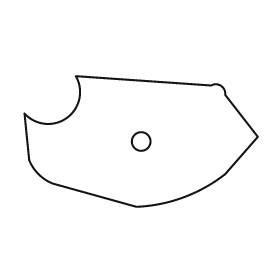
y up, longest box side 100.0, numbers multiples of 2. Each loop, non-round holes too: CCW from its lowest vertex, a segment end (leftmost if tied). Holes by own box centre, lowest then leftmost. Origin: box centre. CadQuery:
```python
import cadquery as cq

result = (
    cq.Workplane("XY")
    .moveTo(-2.0, -28.0)
    .threePointArc((18.0, -24.0), (36.0, -14.0))
    .lineTo(50.0, 2.0)
    .lineTo(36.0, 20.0)
    .threePointArc((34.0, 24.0), (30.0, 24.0))
    .lineTo(-28.0, 28.0)
    .threePointArc((-32.0, 10.0), (-50.0, 12.0))
    .lineTo(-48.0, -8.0)
    .threePointArc((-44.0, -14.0), (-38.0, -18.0))
    .close()
    .moveTo(0.0, 0.0)
    .circle(4.0)
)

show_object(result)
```